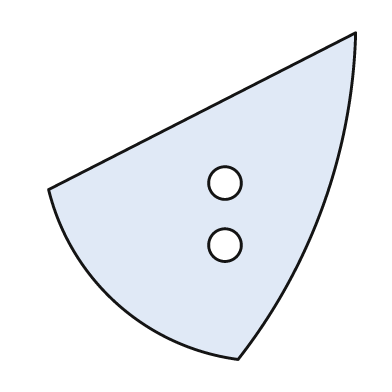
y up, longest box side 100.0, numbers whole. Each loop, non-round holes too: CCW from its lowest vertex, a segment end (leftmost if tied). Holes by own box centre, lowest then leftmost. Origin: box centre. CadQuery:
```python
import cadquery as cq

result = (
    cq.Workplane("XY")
    .moveTo(11.0, -50.0)
    .threePointArc((37.0, -3.0), (47.0, 50.0))
    .lineTo(-47.0, 2.0)
    .threePointArc((-26.0, -33.0), (11.0, -50.0))
    .close()
    .moveTo(7.0, -15.0)
    .circle(5.0)
    .moveTo(7.0, 4.0)
    .circle(5.0)
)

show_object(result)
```